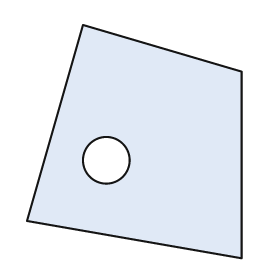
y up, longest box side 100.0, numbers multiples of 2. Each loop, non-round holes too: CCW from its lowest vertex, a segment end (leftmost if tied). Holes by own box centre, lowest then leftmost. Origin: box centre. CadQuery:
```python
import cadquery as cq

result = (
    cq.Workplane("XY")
    .moveTo(46.0, -50.0)
    .lineTo(46.0, 30.0)
    .lineTo(-22.0, 50.0)
    .lineTo(-46.0, -34.0)
    .close()
    .moveTo(-12.0, -8.0)
    .circle(10.0)
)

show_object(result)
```